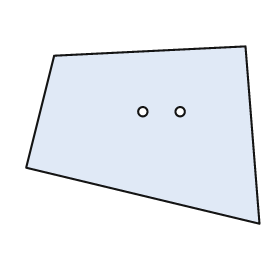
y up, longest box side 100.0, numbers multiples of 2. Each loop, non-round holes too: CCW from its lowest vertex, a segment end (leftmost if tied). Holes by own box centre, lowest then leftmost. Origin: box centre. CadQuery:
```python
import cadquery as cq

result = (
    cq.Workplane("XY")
    .moveTo(50.0, -38.0)
    .lineTo(44.0, 38.0)
    .lineTo(-38.0, 34.0)
    .lineTo(-50.0, -14.0)
    .close()
    .moveTo(0.0, 10.0)
    .circle(2.0)
    .moveTo(16.0, 10.0)
    .circle(2.0)
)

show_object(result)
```